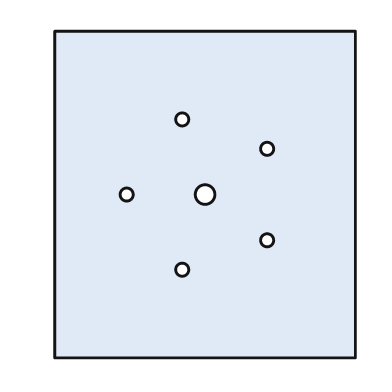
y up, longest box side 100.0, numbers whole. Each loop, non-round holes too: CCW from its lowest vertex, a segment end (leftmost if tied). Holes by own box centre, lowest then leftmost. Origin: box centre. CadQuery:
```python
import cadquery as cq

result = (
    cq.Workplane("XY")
    .moveTo(-46.0, -50.0)
    .lineTo(46.0, -50.0)
    .lineTo(46.0, 50.0)
    .lineTo(-46.0, 50.0)
    .close()
    .moveTo(-7.0, -23.0)
    .circle(2.0)
    .moveTo(19.0, -14.0)
    .circle(2.0)
    .moveTo(-24.0, 0.0)
    .circle(2.0)
    .moveTo(0.0, 0.0)
    .circle(3.0)
    .moveTo(19.0, 14.0)
    .circle(2.0)
    .moveTo(-7.0, 23.0)
    .circle(2.0)
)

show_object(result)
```